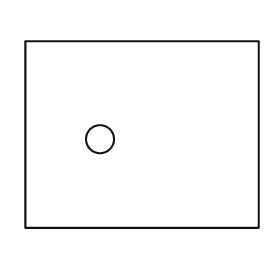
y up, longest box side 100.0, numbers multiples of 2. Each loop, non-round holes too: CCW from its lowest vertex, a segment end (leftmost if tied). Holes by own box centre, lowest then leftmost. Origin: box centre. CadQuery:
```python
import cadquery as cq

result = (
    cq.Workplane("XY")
    .moveTo(-50.0, -40.0)
    .lineTo(50.0, -40.0)
    .lineTo(50.0, 40.0)
    .lineTo(-50.0, 40.0)
    .close()
    .moveTo(-18.0, -2.0)
    .circle(6.0)
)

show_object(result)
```